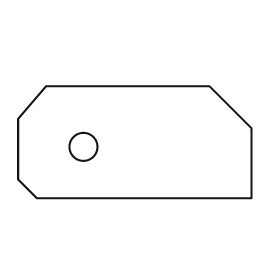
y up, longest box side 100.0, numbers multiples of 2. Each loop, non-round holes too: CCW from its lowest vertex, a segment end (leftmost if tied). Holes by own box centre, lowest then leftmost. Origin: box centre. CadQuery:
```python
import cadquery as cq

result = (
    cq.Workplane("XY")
    .moveTo(-42.0, -24.0)
    .lineTo(50.0, -24.0)
    .lineTo(50.0, 6.0)
    .lineTo(32.0, 24.0)
    .lineTo(-38.0, 24.0)
    .lineTo(-50.0, 10.0)
    .lineTo(-50.0, -16.0)
    .close()
    .moveTo(-22.0, -2.0)
    .circle(6.0)
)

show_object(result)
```